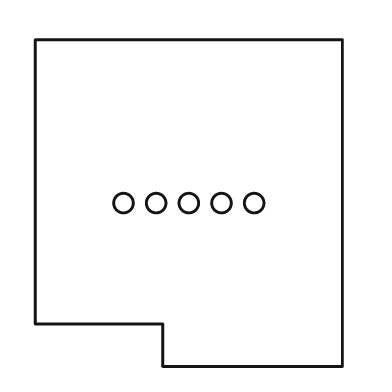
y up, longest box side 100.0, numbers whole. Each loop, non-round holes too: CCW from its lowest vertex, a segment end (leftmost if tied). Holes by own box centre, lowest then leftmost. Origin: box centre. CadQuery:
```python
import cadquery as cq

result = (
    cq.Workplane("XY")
    .moveTo(-8.0, -50.0)
    .lineTo(47.0, -50.0)
    .lineTo(47.0, 50.0)
    .lineTo(-47.0, 50.0)
    .lineTo(-47.0, -37.0)
    .lineTo(-8.0, -37.0)
    .close()
    .moveTo(-20.0, 0.0)
    .circle(3.0)
    .moveTo(-10.0, 0.0)
    .circle(3.0)
    .moveTo(0.0, 0.0)
    .circle(3.0)
    .moveTo(10.0, 0.0)
    .circle(3.0)
    .moveTo(20.0, 0.0)
    .circle(3.0)
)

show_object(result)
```